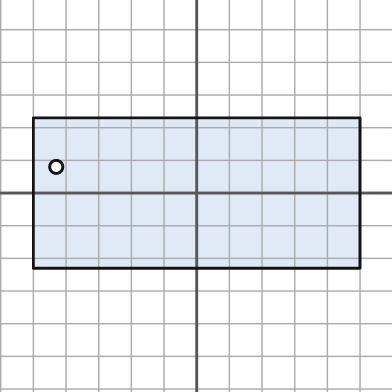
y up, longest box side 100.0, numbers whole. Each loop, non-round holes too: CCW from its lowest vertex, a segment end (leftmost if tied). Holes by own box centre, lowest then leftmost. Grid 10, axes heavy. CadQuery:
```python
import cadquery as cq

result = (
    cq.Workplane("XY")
    .moveTo(-50.0, -23.0)
    .lineTo(50.0, -23.0)
    .lineTo(50.0, 23.0)
    .lineTo(-50.0, 23.0)
    .close()
    .moveTo(-43.0, 8.0)
    .circle(2.0)
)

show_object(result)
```